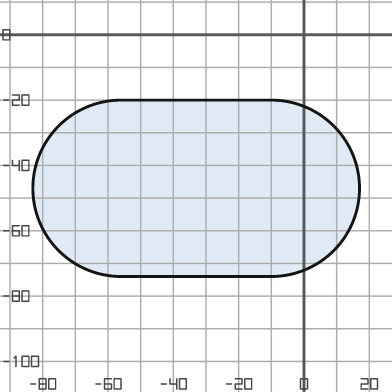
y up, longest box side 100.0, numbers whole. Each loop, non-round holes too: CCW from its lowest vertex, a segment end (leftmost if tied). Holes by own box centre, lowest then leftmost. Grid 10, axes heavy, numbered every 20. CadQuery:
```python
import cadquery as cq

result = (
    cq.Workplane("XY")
    .moveTo(-56.0, -74.0)
    .lineTo(-10.0, -74.0)
    .threePointArc((17.0, -47.0), (-10.0, -20.0))
    .lineTo(-56.0, -20.0)
    .threePointArc((-83.0, -47.0), (-56.0, -74.0))
    .close()
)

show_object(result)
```